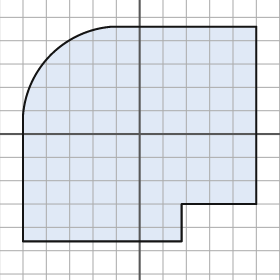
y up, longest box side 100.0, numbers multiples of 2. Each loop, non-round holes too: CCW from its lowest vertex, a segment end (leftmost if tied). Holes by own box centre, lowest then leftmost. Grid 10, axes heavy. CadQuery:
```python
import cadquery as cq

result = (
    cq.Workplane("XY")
    .moveTo(-50.0, -46.0)
    .lineTo(18.0, -46.0)
    .lineTo(18.0, -30.0)
    .lineTo(50.0, -30.0)
    .lineTo(50.0, 46.0)
    .lineTo(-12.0, 46.0)
    .threePointArc((-38.0, 34.0), (-50.0, 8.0))
    .close()
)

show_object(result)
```